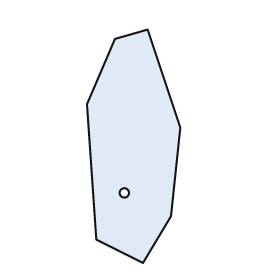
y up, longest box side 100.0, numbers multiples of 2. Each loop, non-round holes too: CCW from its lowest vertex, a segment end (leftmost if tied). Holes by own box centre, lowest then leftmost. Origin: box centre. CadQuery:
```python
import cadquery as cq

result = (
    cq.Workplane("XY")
    .moveTo(4.0, -50.0)
    .lineTo(16.0, -30.0)
    .lineTo(20.0, 8.0)
    .lineTo(6.0, 50.0)
    .lineTo(-8.0, 46.0)
    .lineTo(-20.0, 18.0)
    .lineTo(-16.0, -40.0)
    .close()
    .moveTo(-4.0, -20.0)
    .circle(2.0)
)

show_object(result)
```